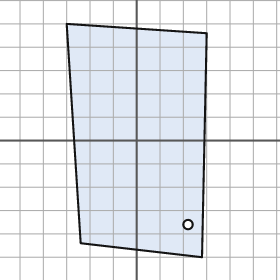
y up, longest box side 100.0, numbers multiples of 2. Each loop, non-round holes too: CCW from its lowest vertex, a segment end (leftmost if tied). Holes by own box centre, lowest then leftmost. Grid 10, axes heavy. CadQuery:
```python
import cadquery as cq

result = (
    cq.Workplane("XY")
    .moveTo(28.0, -50.0)
    .lineTo(30.0, 46.0)
    .lineTo(-30.0, 50.0)
    .lineTo(-24.0, -44.0)
    .close()
    .moveTo(22.0, -36.0)
    .circle(2.0)
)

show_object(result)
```